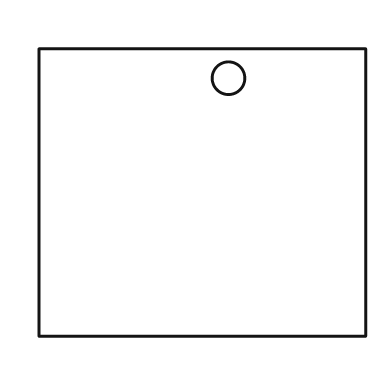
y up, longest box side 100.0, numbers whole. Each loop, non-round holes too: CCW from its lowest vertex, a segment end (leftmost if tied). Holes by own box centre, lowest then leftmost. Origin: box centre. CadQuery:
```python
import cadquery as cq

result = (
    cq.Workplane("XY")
    .moveTo(-50.0, -44.0)
    .lineTo(50.0, -44.0)
    .lineTo(50.0, 44.0)
    .lineTo(-50.0, 44.0)
    .close()
    .moveTo(8.0, 35.0)
    .circle(5.0)
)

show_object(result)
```